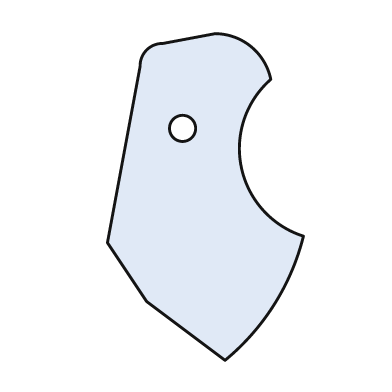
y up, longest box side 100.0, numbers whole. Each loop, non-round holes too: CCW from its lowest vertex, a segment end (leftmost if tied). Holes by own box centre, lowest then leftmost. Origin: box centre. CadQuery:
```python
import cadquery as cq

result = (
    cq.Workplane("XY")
    .moveTo(6.0, -50.0)
    .threePointArc((21.0, -33.0), (30.0, -12.0))
    .threePointArc((11.0, 9.0), (20.0, 36.0))
    .threePointArc((14.0, 46.0), (3.0, 50.0))
    .lineTo(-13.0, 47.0)
    .threePointArc((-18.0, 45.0), (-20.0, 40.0))
    .lineTo(-30.0, -14.0)
    .lineTo(-18.0, -32.0)
    .close()
    .moveTo(-7.0, 21.0)
    .circle(4.0)
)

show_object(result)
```